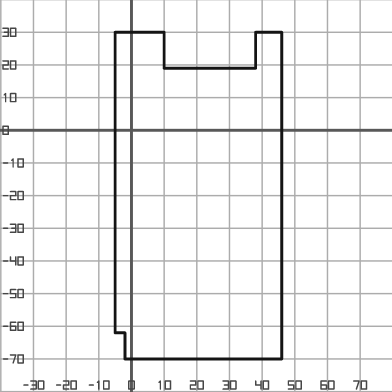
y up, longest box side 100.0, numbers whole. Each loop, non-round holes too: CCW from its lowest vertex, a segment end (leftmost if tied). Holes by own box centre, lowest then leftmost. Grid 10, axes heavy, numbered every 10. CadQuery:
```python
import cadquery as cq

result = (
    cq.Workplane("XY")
    .moveTo(-2.0, -70.0)
    .lineTo(46.0, -70.0)
    .lineTo(46.0, 30.0)
    .lineTo(38.0, 30.0)
    .lineTo(38.0, 19.0)
    .lineTo(10.0, 19.0)
    .lineTo(10.0, 30.0)
    .lineTo(-5.0, 30.0)
    .lineTo(-5.0, -62.0)
    .lineTo(-2.0, -62.0)
    .close()
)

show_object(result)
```